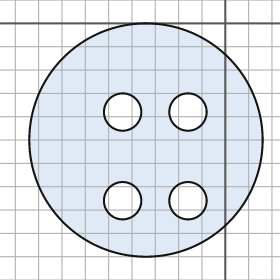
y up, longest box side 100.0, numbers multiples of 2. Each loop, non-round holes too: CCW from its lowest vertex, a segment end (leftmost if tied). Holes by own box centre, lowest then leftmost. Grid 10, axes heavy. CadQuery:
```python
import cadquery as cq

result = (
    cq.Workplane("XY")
    .moveTo(-34.0, -50.0)
    .circle(50.0)
    .moveTo(-44.0, -76.0)
    .circle(8.0)
    .moveTo(-16.0, -76.0)
    .circle(8.0)
    .moveTo(-44.0, -38.0)
    .circle(8.0)
    .moveTo(-16.0, -38.0)
    .circle(8.0)
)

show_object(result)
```